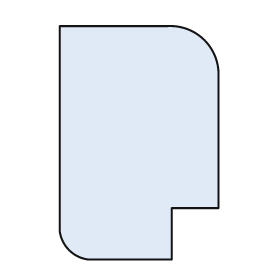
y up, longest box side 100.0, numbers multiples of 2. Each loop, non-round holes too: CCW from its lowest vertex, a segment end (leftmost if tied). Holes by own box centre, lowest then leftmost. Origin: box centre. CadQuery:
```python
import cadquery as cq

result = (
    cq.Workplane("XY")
    .moveTo(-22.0, -50.0)
    .lineTo(14.0, -50.0)
    .lineTo(14.0, -28.0)
    .lineTo(34.0, -28.0)
    .lineTo(34.0, 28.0)
    .threePointArc((28.0, 44.0), (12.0, 50.0))
    .lineTo(-34.0, 50.0)
    .lineTo(-34.0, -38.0)
    .threePointArc((-30.0, -46.0), (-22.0, -50.0))
    .close()
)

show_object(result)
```